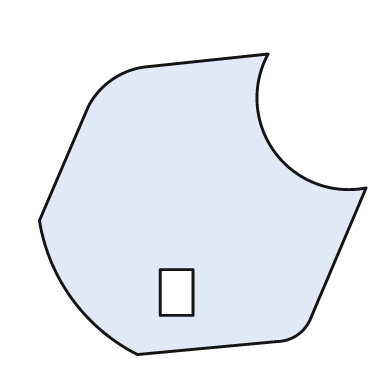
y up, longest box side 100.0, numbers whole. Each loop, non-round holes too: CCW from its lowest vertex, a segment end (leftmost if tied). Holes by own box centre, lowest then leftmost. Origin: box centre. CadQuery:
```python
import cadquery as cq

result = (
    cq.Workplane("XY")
    .moveTo(-20.0, -46.0)
    .lineTo(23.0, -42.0)
    .threePointArc((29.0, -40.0), (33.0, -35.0))
    .lineTo(50.0, 5.0)
    .threePointArc((22.0, 16.0), (20.0, 46.0))
    .lineTo(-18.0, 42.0)
    .threePointArc((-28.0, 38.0), (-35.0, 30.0))
    .lineTo(-50.0, -5.0)
    .threePointArc((-40.0, -29.0), (-20.0, -46.0))
    .close()
    .moveTo(-13.0, -34.0)
    .lineTo(-3.0, -34.0)
    .lineTo(-3.0, -20.0)
    .lineTo(-13.0, -20.0)
    .close()
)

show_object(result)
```